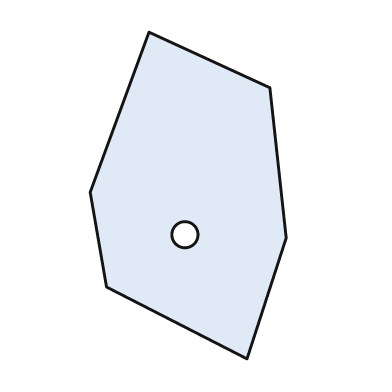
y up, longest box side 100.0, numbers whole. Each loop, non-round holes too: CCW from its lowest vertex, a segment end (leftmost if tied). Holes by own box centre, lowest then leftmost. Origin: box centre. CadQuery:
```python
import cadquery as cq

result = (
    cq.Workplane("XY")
    .moveTo(18.0, -50.0)
    .lineTo(30.0, -13.0)
    .lineTo(25.0, 33.0)
    .lineTo(-12.0, 50.0)
    .lineTo(-30.0, 1.0)
    .lineTo(-25.0, -28.0)
    .close()
    .moveTo(-1.0, -12.0)
    .circle(4.0)
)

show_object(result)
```